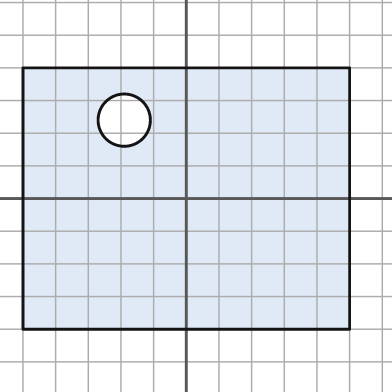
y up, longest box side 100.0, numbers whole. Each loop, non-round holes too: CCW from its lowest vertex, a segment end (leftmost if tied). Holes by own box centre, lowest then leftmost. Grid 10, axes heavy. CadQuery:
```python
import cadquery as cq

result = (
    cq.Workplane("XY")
    .moveTo(-50.0, -40.0)
    .lineTo(50.0, -40.0)
    .lineTo(50.0, 40.0)
    .lineTo(-50.0, 40.0)
    .close()
    .moveTo(-19.0, 24.0)
    .circle(8.0)
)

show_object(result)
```